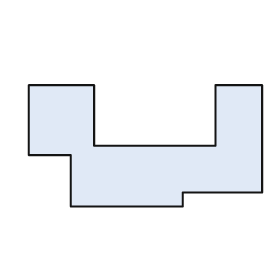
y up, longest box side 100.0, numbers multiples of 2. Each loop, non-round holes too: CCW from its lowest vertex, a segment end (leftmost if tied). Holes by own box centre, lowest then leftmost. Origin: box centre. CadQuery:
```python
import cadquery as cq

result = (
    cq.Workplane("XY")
    .moveTo(-32.0, -26.0)
    .lineTo(16.0, -26.0)
    .lineTo(16.0, -20.0)
    .lineTo(50.0, -20.0)
    .lineTo(50.0, 26.0)
    .lineTo(30.0, 26.0)
    .lineTo(30.0, 0.0)
    .lineTo(-22.0, 0.0)
    .lineTo(-22.0, 26.0)
    .lineTo(-50.0, 26.0)
    .lineTo(-50.0, -4.0)
    .lineTo(-32.0, -4.0)
    .close()
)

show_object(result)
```